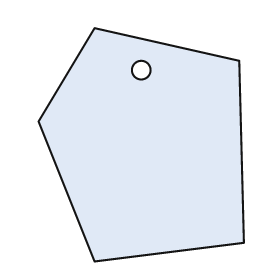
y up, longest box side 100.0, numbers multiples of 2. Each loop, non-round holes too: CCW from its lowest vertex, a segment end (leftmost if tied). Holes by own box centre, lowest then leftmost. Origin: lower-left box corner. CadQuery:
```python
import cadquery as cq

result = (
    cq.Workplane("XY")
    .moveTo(24.0, 0.0)
    .lineTo(88.0, 8.0)
    .lineTo(86.0, 86.0)
    .lineTo(24.0, 100.0)
    .lineTo(0.0, 60.0)
    .close()
    .moveTo(44.0, 82.0)
    .circle(4.0)
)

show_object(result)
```